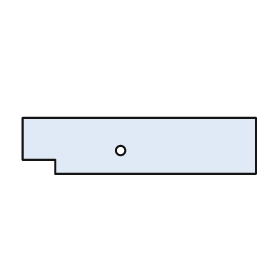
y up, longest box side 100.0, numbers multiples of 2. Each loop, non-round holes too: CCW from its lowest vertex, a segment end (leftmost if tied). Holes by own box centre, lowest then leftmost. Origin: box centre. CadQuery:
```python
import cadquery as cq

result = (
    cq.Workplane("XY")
    .moveTo(-36.0, -12.0)
    .lineTo(50.0, -12.0)
    .lineTo(50.0, 12.0)
    .lineTo(-50.0, 12.0)
    .lineTo(-50.0, -6.0)
    .lineTo(-36.0, -6.0)
    .close()
    .moveTo(-8.0, -2.0)
    .circle(2.0)
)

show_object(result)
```